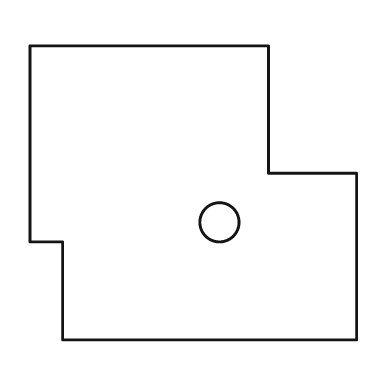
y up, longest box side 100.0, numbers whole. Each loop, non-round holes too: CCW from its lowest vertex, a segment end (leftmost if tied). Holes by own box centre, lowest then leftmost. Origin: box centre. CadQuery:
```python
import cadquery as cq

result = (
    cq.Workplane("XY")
    .moveTo(-40.0, -45.0)
    .lineTo(50.0, -45.0)
    .lineTo(50.0, 6.0)
    .lineTo(23.0, 6.0)
    .lineTo(23.0, 45.0)
    .lineTo(-50.0, 45.0)
    .lineTo(-50.0, -15.0)
    .lineTo(-40.0, -15.0)
    .close()
    .moveTo(8.0, -9.0)
    .circle(6.0)
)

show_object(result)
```